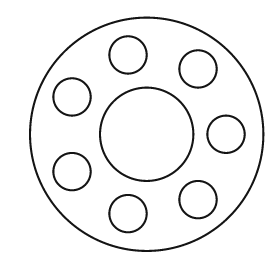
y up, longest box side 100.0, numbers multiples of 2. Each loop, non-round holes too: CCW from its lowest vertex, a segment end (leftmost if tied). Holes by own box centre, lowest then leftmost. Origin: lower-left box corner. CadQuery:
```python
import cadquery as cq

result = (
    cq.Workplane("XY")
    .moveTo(50.0, 50.0)
    .circle(50.0)
    .moveTo(42.0, 16.0)
    .circle(8.0)
    .moveTo(72.0, 22.0)
    .circle(8.0)
    .moveTo(18.0, 34.0)
    .circle(8.0)
    .moveTo(50.0, 50.0)
    .circle(20.0)
    .moveTo(84.0, 50.0)
    .circle(8.0)
    .moveTo(18.0, 66.0)
    .circle(8.0)
    .moveTo(72.0, 78.0)
    .circle(8.0)
    .moveTo(42.0, 84.0)
    .circle(8.0)
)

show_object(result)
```